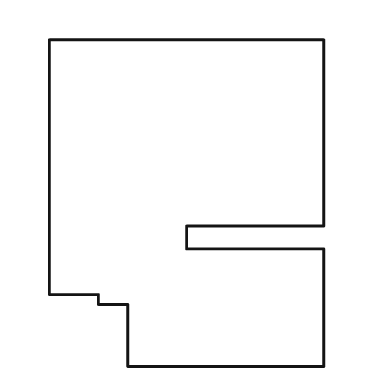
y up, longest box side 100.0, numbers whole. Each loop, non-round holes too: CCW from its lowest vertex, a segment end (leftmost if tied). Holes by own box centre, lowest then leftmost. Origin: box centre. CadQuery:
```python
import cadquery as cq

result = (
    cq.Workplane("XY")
    .moveTo(-18.0, -50.0)
    .lineTo(42.0, -50.0)
    .lineTo(42.0, -14.0)
    .lineTo(0.0, -14.0)
    .lineTo(0.0, -7.0)
    .lineTo(42.0, -7.0)
    .lineTo(42.0, 50.0)
    .lineTo(-42.0, 50.0)
    .lineTo(-42.0, -28.0)
    .lineTo(-27.0, -28.0)
    .lineTo(-27.0, -31.0)
    .lineTo(-18.0, -31.0)
    .close()
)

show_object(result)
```